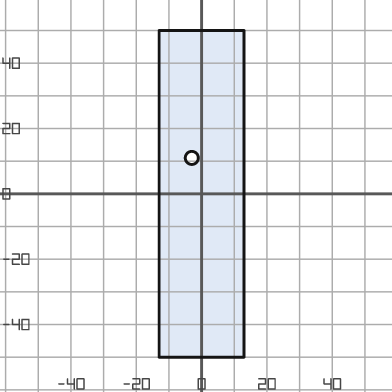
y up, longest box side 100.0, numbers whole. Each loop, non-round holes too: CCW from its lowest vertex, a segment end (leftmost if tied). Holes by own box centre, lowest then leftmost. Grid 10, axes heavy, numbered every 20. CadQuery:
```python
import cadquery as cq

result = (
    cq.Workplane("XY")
    .moveTo(-13.0, -50.0)
    .lineTo(13.0, -50.0)
    .lineTo(13.0, 50.0)
    .lineTo(-13.0, 50.0)
    .close()
    .moveTo(-3.0, 11.0)
    .circle(2.0)
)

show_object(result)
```